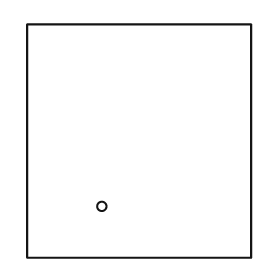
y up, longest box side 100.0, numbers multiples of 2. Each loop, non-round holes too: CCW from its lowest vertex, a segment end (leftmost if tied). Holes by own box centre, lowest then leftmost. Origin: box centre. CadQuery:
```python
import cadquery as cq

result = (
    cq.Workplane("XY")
    .moveTo(-48.0, -50.0)
    .lineTo(48.0, -50.0)
    .lineTo(48.0, 50.0)
    .lineTo(-48.0, 50.0)
    .close()
    .moveTo(-16.0, -28.0)
    .circle(2.0)
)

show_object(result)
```